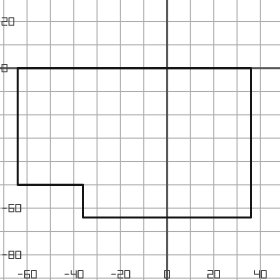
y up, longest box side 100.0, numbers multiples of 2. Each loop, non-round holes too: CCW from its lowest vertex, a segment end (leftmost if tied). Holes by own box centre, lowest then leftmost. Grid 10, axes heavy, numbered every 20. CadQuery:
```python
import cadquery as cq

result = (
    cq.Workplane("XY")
    .moveTo(-36.0, -64.0)
    .lineTo(36.0, -64.0)
    .lineTo(36.0, 0.0)
    .lineTo(-64.0, 0.0)
    .lineTo(-64.0, -50.0)
    .lineTo(-36.0, -50.0)
    .close()
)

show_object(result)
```